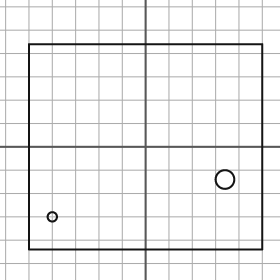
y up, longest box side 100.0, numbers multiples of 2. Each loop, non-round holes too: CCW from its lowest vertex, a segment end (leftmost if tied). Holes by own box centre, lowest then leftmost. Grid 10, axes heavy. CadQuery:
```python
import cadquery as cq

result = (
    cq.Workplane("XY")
    .moveTo(-50.0, -44.0)
    .lineTo(50.0, -44.0)
    .lineTo(50.0, 44.0)
    .lineTo(-50.0, 44.0)
    .close()
    .moveTo(-40.0, -30.0)
    .circle(2.0)
    .moveTo(34.0, -14.0)
    .circle(4.0)
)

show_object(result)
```